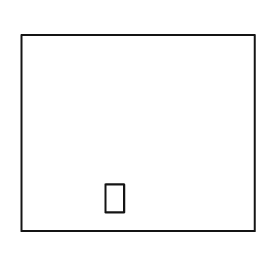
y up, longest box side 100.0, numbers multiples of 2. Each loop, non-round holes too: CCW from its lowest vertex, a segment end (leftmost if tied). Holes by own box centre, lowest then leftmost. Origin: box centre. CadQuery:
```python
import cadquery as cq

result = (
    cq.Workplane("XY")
    .moveTo(-50.0, -42.0)
    .lineTo(50.0, -42.0)
    .lineTo(50.0, 42.0)
    .lineTo(-50.0, 42.0)
    .close()
    .moveTo(-14.0, -34.0)
    .lineTo(-6.0, -34.0)
    .lineTo(-6.0, -22.0)
    .lineTo(-14.0, -22.0)
    .close()
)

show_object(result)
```